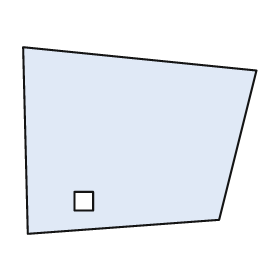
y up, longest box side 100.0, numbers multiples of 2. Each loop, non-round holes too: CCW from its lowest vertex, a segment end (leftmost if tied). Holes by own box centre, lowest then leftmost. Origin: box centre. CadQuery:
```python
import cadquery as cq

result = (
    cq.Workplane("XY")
    .moveTo(-48.0, -40.0)
    .lineTo(34.0, -34.0)
    .lineTo(50.0, 30.0)
    .lineTo(-50.0, 40.0)
    .close()
    .moveTo(-28.0, -30.0)
    .lineTo(-20.0, -30.0)
    .lineTo(-20.0, -22.0)
    .lineTo(-28.0, -22.0)
    .close()
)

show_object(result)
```